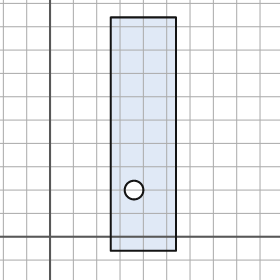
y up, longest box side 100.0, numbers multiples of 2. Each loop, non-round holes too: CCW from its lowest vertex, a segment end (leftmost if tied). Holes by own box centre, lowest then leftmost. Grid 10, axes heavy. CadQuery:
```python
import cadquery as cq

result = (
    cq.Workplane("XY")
    .moveTo(26.0, -6.0)
    .lineTo(54.0, -6.0)
    .lineTo(54.0, 94.0)
    .lineTo(26.0, 94.0)
    .close()
    .moveTo(36.0, 20.0)
    .circle(4.0)
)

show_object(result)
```